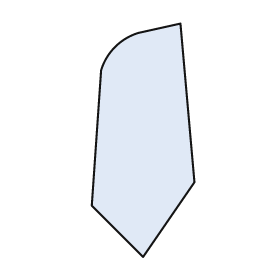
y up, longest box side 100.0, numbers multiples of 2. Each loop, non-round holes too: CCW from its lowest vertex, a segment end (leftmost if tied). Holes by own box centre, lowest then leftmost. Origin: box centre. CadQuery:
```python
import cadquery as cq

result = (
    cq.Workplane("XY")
    .moveTo(0.0, -50.0)
    .lineTo(22.0, -18.0)
    .lineTo(16.0, 50.0)
    .lineTo(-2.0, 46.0)
    .threePointArc((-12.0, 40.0), (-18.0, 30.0))
    .lineTo(-22.0, -28.0)
    .close()
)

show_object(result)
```